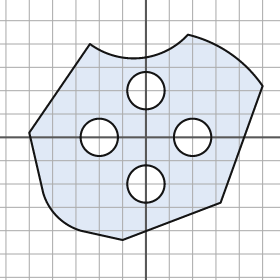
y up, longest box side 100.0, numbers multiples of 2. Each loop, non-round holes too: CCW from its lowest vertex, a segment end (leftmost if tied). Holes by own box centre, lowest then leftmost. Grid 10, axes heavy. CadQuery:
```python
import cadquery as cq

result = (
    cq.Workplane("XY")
    .moveTo(-10.0, -44.0)
    .lineTo(32.0, -28.0)
    .lineTo(50.0, 22.0)
    .threePointArc((36.0, 36.0), (18.0, 44.0))
    .threePointArc((-2.0, 34.0), (-24.0, 40.0))
    .lineTo(-50.0, 2.0)
    .lineTo(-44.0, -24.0)
    .threePointArc((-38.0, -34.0), (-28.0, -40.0))
    .close()
    .moveTo(0.0, -20.0)
    .circle(8.0)
    .moveTo(-20.0, 0.0)
    .circle(8.0)
    .moveTo(20.0, 0.0)
    .circle(8.0)
    .moveTo(0.0, 20.0)
    .circle(8.0)
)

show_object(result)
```